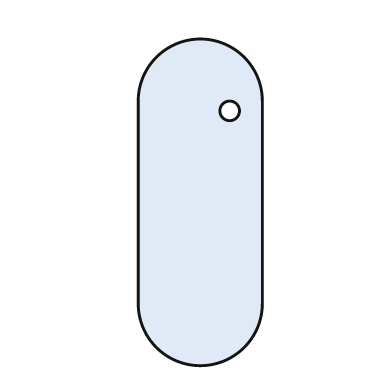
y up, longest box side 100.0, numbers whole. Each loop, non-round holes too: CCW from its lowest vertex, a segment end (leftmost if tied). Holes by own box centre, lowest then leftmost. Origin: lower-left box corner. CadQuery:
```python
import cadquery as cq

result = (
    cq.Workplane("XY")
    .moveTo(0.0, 19.0)
    .threePointArc((19.0, 0.0), (38.0, 19.0))
    .lineTo(38.0, 81.0)
    .threePointArc((19.0, 100.0), (0.0, 81.0))
    .close()
    .moveTo(28.0, 78.0)
    .circle(3.0)
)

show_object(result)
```